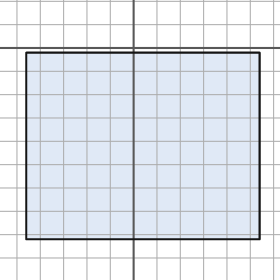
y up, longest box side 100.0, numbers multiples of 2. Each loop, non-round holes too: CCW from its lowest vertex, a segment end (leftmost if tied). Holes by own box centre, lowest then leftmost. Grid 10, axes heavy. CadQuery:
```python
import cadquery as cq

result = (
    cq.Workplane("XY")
    .moveTo(-46.0, -82.0)
    .lineTo(54.0, -82.0)
    .lineTo(54.0, -2.0)
    .lineTo(-46.0, -2.0)
    .close()
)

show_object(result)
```